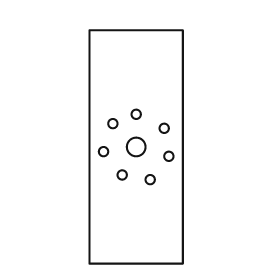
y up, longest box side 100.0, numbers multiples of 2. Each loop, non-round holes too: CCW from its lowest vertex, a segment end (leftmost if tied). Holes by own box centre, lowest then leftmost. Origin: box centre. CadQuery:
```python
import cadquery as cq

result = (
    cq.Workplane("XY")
    .moveTo(-20.0, -50.0)
    .lineTo(20.0, -50.0)
    .lineTo(20.0, 50.0)
    .lineTo(-20.0, 50.0)
    .close()
    .moveTo(6.0, -14.0)
    .circle(2.0)
    .moveTo(-6.0, -12.0)
    .circle(2.0)
    .moveTo(14.0, -4.0)
    .circle(2.0)
    .moveTo(-14.0, -2.0)
    .circle(2.0)
    .moveTo(0.0, 0.0)
    .circle(4.0)
    .moveTo(12.0, 8.0)
    .circle(2.0)
    .moveTo(-10.0, 10.0)
    .circle(2.0)
    .moveTo(0.0, 14.0)
    .circle(2.0)
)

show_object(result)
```